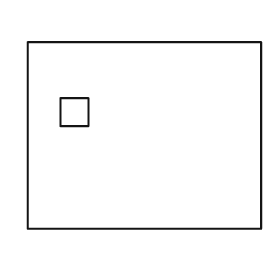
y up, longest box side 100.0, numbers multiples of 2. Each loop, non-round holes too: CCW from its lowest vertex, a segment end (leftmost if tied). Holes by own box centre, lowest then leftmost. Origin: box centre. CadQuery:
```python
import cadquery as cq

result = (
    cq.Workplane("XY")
    .moveTo(-50.0, -40.0)
    .lineTo(50.0, -40.0)
    .lineTo(50.0, 40.0)
    .lineTo(-50.0, 40.0)
    .close()
    .moveTo(-36.0, 4.0)
    .lineTo(-24.0, 4.0)
    .lineTo(-24.0, 16.0)
    .lineTo(-36.0, 16.0)
    .close()
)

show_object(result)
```